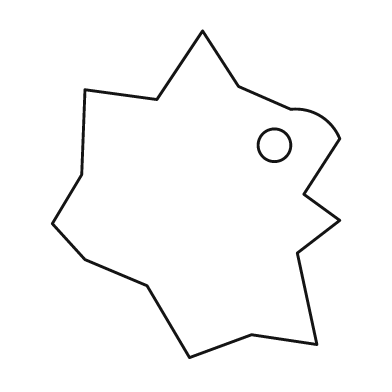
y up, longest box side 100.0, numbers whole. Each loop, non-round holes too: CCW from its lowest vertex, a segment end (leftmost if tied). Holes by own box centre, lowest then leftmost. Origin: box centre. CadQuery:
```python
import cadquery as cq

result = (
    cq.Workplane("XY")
    .moveTo(-2.0, -50.0)
    .lineTo(17.0, -43.0)
    .lineTo(37.0, -46.0)
    .lineTo(31.0, -18.0)
    .lineTo(44.0, -8.0)
    .lineTo(33.0, 0.0)
    .lineTo(44.0, 17.0)
    .threePointArc((38.0, 24.0), (29.0, 26.0))
    .lineTo(13.0, 33.0)
    .lineTo(2.0, 50.0)
    .lineTo(-12.0, 29.0)
    .lineTo(-34.0, 32.0)
    .lineTo(-35.0, 6.0)
    .lineTo(-44.0, -9.0)
    .lineTo(-34.0, -20.0)
    .lineTo(-15.0, -28.0)
    .close()
    .moveTo(24.0, 15.0)
    .circle(5.0)
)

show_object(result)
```